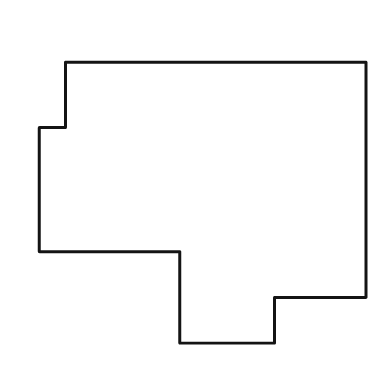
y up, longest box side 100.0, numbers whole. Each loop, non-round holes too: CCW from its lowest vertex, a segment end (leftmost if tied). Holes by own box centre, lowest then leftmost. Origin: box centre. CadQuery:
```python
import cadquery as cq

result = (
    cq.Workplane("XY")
    .moveTo(-7.0, -43.0)
    .lineTo(22.0, -43.0)
    .lineTo(22.0, -29.0)
    .lineTo(50.0, -29.0)
    .lineTo(50.0, 43.0)
    .lineTo(-42.0, 43.0)
    .lineTo(-42.0, 23.0)
    .lineTo(-50.0, 23.0)
    .lineTo(-50.0, -15.0)
    .lineTo(-7.0, -15.0)
    .close()
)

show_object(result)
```